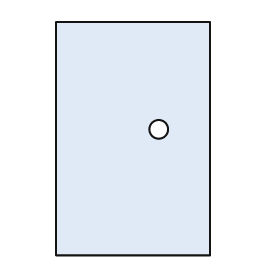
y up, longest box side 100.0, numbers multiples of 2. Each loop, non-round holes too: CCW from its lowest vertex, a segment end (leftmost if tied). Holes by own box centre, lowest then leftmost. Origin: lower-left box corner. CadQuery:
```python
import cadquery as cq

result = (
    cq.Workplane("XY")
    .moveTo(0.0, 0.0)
    .lineTo(66.0, 0.0)
    .lineTo(66.0, 100.0)
    .lineTo(0.0, 100.0)
    .close()
    .moveTo(44.0, 54.0)
    .circle(4.0)
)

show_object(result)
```